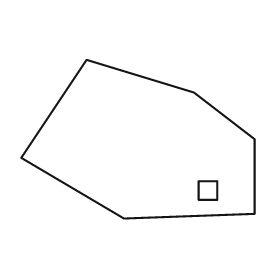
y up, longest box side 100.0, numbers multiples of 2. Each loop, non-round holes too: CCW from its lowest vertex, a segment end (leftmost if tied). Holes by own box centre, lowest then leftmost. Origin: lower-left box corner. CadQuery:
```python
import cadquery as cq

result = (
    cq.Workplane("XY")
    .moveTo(44.0, 0.0)
    .lineTo(100.0, 2.0)
    .lineTo(100.0, 34.0)
    .lineTo(74.0, 54.0)
    .lineTo(28.0, 68.0)
    .lineTo(0.0, 26.0)
    .close()
    .moveTo(76.0, 8.0)
    .lineTo(84.0, 8.0)
    .lineTo(84.0, 16.0)
    .lineTo(76.0, 16.0)
    .close()
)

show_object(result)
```